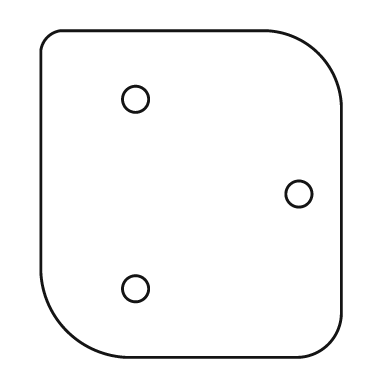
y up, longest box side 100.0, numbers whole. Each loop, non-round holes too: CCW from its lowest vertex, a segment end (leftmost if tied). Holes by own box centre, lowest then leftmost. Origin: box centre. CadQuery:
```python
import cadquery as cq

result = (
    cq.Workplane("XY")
    .moveTo(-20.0, -50.0)
    .lineTo(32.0, -50.0)
    .threePointArc((42.0, -46.0), (46.0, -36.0))
    .lineTo(46.0, 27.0)
    .threePointArc((39.0, 43.0), (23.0, 50.0))
    .lineTo(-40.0, 50.0)
    .threePointArc((-44.0, 48.0), (-46.0, 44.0))
    .lineTo(-46.0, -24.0)
    .threePointArc((-38.0, -42.0), (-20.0, -50.0))
    .close()
    .moveTo(-17.0, -29.0)
    .circle(4.0)
    .moveTo(33.0, 0.0)
    .circle(4.0)
    .moveTo(-17.0, 29.0)
    .circle(4.0)
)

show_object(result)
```